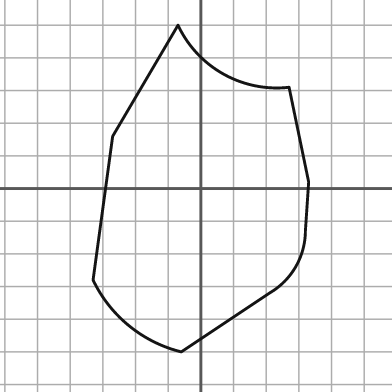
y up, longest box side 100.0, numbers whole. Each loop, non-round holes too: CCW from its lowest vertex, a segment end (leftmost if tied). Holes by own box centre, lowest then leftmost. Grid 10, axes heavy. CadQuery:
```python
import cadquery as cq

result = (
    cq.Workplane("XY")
    .moveTo(-6.0, -50.0)
    .lineTo(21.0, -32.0)
    .threePointArc((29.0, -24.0), (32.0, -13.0))
    .lineTo(33.0, 2.0)
    .lineTo(27.0, 31.0)
    .threePointArc((7.0, 35.0), (-7.0, 50.0))
    .lineTo(-27.0, 16.0)
    .lineTo(-33.0, -28.0)
    .threePointArc((-22.0, -42.0), (-6.0, -50.0))
    .close()
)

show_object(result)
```